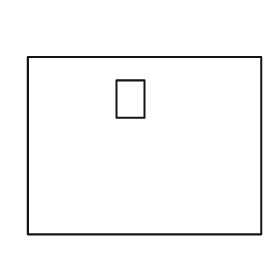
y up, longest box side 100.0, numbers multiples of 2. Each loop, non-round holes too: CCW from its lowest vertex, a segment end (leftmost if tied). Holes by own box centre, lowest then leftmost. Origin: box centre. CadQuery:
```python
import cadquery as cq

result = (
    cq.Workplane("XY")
    .moveTo(-50.0, -38.0)
    .lineTo(50.0, -38.0)
    .lineTo(50.0, 38.0)
    .lineTo(-50.0, 38.0)
    .close()
    .moveTo(-12.0, 12.0)
    .lineTo(0.0, 12.0)
    .lineTo(0.0, 28.0)
    .lineTo(-12.0, 28.0)
    .close()
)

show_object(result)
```